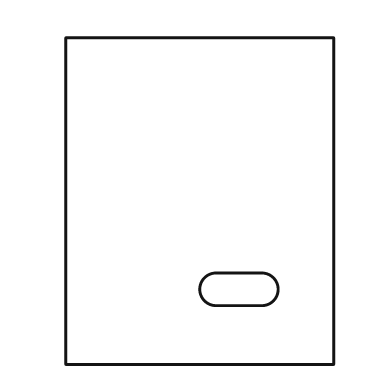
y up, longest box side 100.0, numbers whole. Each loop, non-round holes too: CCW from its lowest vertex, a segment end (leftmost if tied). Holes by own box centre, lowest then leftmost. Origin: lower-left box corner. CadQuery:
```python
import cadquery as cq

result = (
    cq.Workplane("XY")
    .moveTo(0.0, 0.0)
    .lineTo(82.0, 0.0)
    .lineTo(82.0, 100.0)
    .lineTo(0.0, 100.0)
    .close()
    .moveTo(46.0, 18.0)
    .lineTo(60.0, 18.0)
    .threePointArc((65.0, 23.0), (60.0, 28.0))
    .lineTo(46.0, 28.0)
    .threePointArc((41.0, 23.0), (46.0, 18.0))
    .close()
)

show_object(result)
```